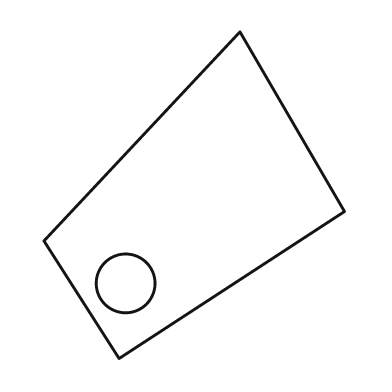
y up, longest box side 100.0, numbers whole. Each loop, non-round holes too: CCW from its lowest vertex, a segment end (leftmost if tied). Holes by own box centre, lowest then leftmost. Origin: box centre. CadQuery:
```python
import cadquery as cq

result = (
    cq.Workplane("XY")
    .moveTo(-23.0, -50.0)
    .lineTo(46.0, -5.0)
    .lineTo(14.0, 50.0)
    .lineTo(-46.0, -14.0)
    .close()
    .moveTo(-21.0, -27.0)
    .circle(9.0)
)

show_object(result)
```